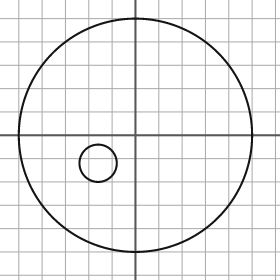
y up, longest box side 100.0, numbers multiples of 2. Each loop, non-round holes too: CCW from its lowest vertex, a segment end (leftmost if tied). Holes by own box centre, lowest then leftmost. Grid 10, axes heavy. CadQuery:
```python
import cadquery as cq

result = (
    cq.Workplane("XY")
    .moveTo(0.0, 0.0)
    .circle(50.0)
    .moveTo(-16.0, -12.0)
    .circle(8.0)
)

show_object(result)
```